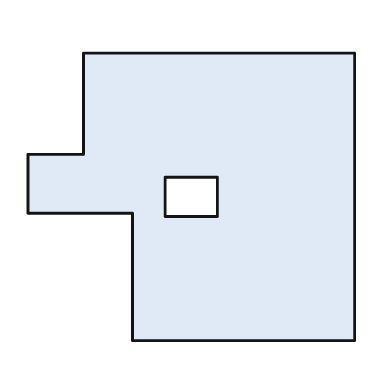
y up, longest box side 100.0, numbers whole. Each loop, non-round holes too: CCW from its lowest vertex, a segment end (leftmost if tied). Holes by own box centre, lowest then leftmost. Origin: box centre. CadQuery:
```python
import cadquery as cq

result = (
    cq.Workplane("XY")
    .moveTo(-18.0, -44.0)
    .lineTo(50.0, -44.0)
    .lineTo(50.0, 44.0)
    .lineTo(-33.0, 44.0)
    .lineTo(-33.0, 13.0)
    .lineTo(-50.0, 13.0)
    .lineTo(-50.0, -5.0)
    .lineTo(-18.0, -5.0)
    .close()
    .moveTo(-8.0, -6.0)
    .lineTo(8.0, -6.0)
    .lineTo(8.0, 6.0)
    .lineTo(-8.0, 6.0)
    .close()
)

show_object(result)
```